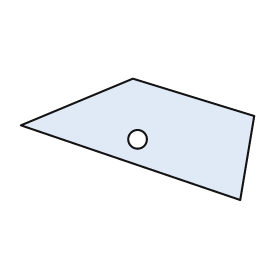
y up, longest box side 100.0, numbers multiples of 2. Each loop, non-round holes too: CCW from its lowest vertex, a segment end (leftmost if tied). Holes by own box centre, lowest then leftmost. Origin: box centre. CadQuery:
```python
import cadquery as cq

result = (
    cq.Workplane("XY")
    .moveTo(44.0, -26.0)
    .lineTo(50.0, 10.0)
    .lineTo(-2.0, 26.0)
    .lineTo(-50.0, 6.0)
    .close()
    .moveTo(0.0, 0.0)
    .circle(4.0)
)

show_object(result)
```